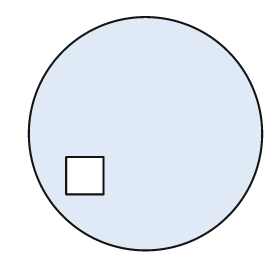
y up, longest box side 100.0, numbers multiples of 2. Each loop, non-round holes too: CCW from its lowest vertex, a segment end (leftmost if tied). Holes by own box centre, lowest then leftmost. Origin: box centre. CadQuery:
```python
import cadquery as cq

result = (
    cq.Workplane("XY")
    .moveTo(0.0, 0.0)
    .circle(50.0)
    .moveTo(-34.0, -26.0)
    .lineTo(-18.0, -26.0)
    .lineTo(-18.0, -10.0)
    .lineTo(-34.0, -10.0)
    .close()
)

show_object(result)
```